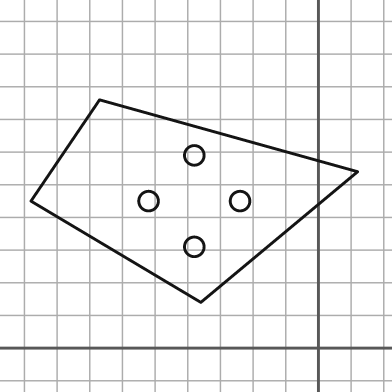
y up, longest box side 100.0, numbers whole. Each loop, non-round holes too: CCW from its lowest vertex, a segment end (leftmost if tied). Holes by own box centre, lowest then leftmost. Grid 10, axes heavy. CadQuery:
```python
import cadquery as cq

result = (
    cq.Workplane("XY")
    .moveTo(-36.0, 14.0)
    .lineTo(12.0, 54.0)
    .lineTo(-67.0, 76.0)
    .lineTo(-88.0, 45.0)
    .close()
    .moveTo(-38.0, 31.0)
    .circle(3.0)
    .moveTo(-52.0, 45.0)
    .circle(3.0)
    .moveTo(-24.0, 45.0)
    .circle(3.0)
    .moveTo(-38.0, 59.0)
    .circle(3.0)
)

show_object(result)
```